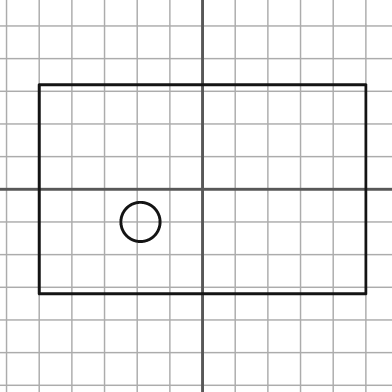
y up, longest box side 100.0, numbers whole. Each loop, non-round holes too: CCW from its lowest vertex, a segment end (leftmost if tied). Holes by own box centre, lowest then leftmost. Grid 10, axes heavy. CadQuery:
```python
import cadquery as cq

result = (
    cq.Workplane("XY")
    .moveTo(-50.0, -32.0)
    .lineTo(50.0, -32.0)
    .lineTo(50.0, 32.0)
    .lineTo(-50.0, 32.0)
    .close()
    .moveTo(-19.0, -10.0)
    .circle(6.0)
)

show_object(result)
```